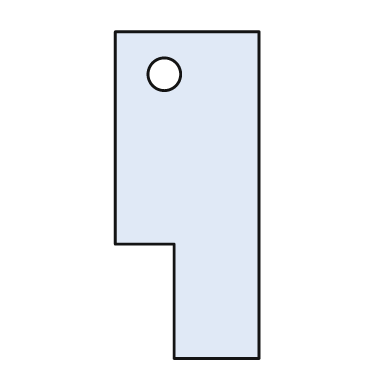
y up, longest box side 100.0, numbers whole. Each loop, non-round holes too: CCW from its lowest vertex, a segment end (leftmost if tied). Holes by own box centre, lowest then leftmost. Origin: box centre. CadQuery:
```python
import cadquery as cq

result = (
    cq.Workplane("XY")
    .moveTo(-4.0, -50.0)
    .lineTo(22.0, -50.0)
    .lineTo(22.0, 50.0)
    .lineTo(-22.0, 50.0)
    .lineTo(-22.0, -15.0)
    .lineTo(-4.0, -15.0)
    .close()
    .moveTo(-7.0, 37.0)
    .circle(5.0)
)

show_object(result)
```